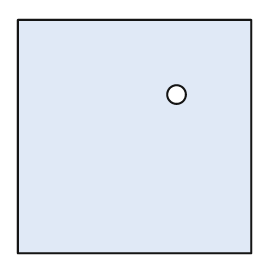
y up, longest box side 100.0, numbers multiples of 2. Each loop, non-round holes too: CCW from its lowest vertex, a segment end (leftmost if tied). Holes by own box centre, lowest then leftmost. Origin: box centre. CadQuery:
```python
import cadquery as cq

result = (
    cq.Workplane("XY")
    .moveTo(-50.0, -50.0)
    .lineTo(50.0, -50.0)
    .lineTo(50.0, 50.0)
    .lineTo(-50.0, 50.0)
    .close()
    .moveTo(18.0, 18.0)
    .circle(4.0)
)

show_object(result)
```